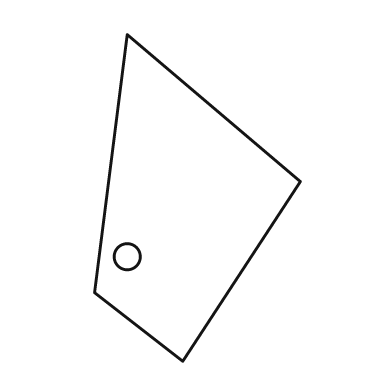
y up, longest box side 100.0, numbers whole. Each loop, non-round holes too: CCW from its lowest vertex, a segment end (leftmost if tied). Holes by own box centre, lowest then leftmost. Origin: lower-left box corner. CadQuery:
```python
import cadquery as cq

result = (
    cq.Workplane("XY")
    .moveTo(27.0, 0.0)
    .lineTo(63.0, 55.0)
    .lineTo(10.0, 100.0)
    .lineTo(0.0, 21.0)
    .close()
    .moveTo(10.0, 32.0)
    .circle(4.0)
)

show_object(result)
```